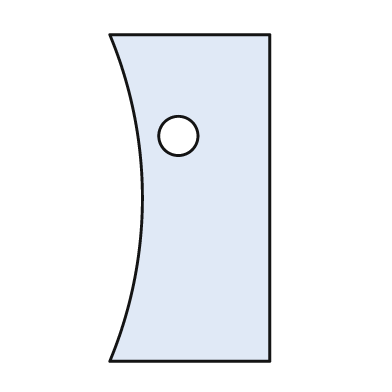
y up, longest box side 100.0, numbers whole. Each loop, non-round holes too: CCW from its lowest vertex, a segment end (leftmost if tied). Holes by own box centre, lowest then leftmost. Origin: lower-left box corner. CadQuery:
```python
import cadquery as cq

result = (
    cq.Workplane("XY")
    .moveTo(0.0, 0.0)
    .lineTo(49.0, 0.0)
    .lineTo(49.0, 100.0)
    .lineTo(0.0, 100.0)
    .threePointArc((10.0, 50.0), (0.0, 0.0))
    .close()
    .moveTo(21.0, 69.0)
    .circle(6.0)
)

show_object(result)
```